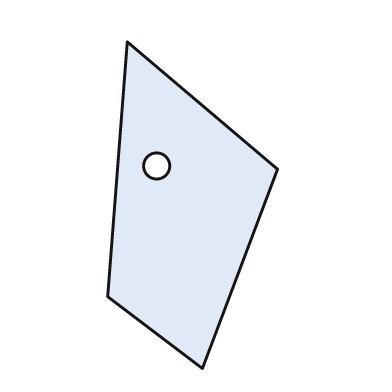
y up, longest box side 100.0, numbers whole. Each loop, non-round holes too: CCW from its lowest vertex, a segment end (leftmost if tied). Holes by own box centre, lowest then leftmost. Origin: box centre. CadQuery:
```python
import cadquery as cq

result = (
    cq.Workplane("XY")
    .moveTo(3.0, -50.0)
    .lineTo(26.0, 11.0)
    .lineTo(-20.0, 50.0)
    .lineTo(-26.0, -28.0)
    .close()
    .moveTo(-11.0, 12.0)
    .circle(4.0)
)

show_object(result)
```